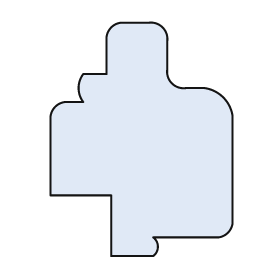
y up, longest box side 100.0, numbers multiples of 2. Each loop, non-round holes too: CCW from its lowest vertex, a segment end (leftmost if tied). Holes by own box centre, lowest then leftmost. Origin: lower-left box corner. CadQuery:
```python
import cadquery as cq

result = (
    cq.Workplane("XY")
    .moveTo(26.0, 0.0)
    .lineTo(44.0, 0.0)
    .threePointArc((46.0, 4.0), (44.0, 8.0))
    .lineTo(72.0, 8.0)
    .threePointArc((76.0, 10.0), (78.0, 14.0))
    .lineTo(78.0, 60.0)
    .threePointArc((74.0, 68.0), (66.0, 72.0))
    .lineTo(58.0, 72.0)
    .threePointArc((52.0, 74.0), (50.0, 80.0))
    .lineTo(50.0, 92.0)
    .threePointArc((48.0, 98.0), (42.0, 100.0))
    .lineTo(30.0, 100.0)
    .threePointArc((26.0, 98.0), (24.0, 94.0))
    .lineTo(24.0, 78.0)
    .lineTo(14.0, 78.0)
    .threePointArc((12.0, 72.0), (14.0, 66.0))
    .lineTo(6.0, 66.0)
    .threePointArc((2.0, 64.0), (0.0, 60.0))
    .lineTo(0.0, 26.0)
    .lineTo(26.0, 26.0)
    .close()
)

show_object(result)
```